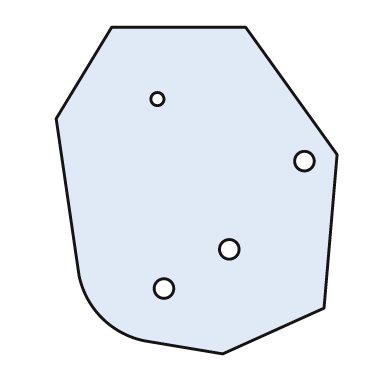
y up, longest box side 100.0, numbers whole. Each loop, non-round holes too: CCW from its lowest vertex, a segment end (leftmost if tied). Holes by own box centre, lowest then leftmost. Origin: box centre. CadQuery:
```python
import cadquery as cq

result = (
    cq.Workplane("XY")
    .moveTo(8.0, -50.0)
    .lineTo(39.0, -36.0)
    .lineTo(43.0, 11.0)
    .lineTo(15.0, 50.0)
    .lineTo(-26.0, 50.0)
    .lineTo(-43.0, 22.0)
    .lineTo(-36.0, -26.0)
    .threePointArc((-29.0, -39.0), (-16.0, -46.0))
    .close()
    .moveTo(-10.0, -30.0)
    .circle(3.0)
    .moveTo(10.0, -18.0)
    .circle(3.0)
    .moveTo(33.0, 9.0)
    .circle(3.0)
    .moveTo(-12.0, 28.0)
    .circle(2.0)
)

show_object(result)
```